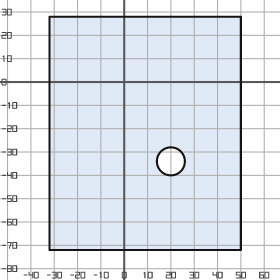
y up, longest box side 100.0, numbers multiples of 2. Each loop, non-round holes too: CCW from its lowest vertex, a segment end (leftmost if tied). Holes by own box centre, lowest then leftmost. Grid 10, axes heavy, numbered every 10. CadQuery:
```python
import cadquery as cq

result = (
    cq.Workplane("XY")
    .moveTo(-32.0, -72.0)
    .lineTo(50.0, -72.0)
    .lineTo(50.0, 28.0)
    .lineTo(-32.0, 28.0)
    .close()
    .moveTo(20.0, -34.0)
    .circle(6.0)
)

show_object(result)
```